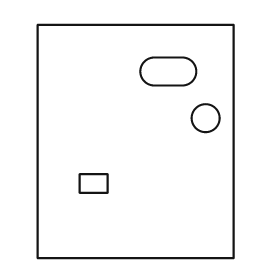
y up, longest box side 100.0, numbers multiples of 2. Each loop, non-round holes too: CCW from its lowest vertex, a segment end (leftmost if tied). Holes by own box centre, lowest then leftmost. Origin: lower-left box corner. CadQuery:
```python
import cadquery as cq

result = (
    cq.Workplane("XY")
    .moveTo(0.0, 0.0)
    .lineTo(84.0, 0.0)
    .lineTo(84.0, 100.0)
    .lineTo(0.0, 100.0)
    .close()
    .moveTo(18.0, 28.0)
    .lineTo(30.0, 28.0)
    .lineTo(30.0, 36.0)
    .lineTo(18.0, 36.0)
    .close()
    .moveTo(72.0, 60.0)
    .circle(6.0)
    .moveTo(50.0, 74.0)
    .lineTo(62.0, 74.0)
    .threePointArc((68.0, 80.0), (62.0, 86.0))
    .lineTo(50.0, 86.0)
    .threePointArc((44.0, 80.0), (50.0, 74.0))
    .close()
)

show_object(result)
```